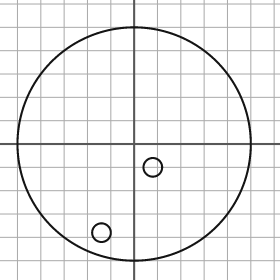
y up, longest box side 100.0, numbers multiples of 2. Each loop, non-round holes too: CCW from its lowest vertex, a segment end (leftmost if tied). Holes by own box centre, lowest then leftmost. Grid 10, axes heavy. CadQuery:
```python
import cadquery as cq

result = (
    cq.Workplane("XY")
    .moveTo(0.0, 0.0)
    .circle(50.0)
    .moveTo(-14.0, -38.0)
    .circle(4.0)
    .moveTo(8.0, -10.0)
    .circle(4.0)
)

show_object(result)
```